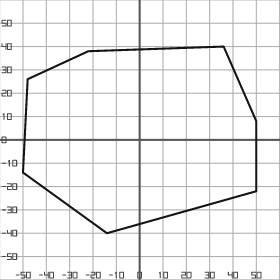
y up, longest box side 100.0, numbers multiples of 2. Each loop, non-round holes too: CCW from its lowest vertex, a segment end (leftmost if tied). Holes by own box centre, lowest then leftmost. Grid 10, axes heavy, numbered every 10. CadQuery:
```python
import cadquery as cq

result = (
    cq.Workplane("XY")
    .moveTo(-14.0, -40.0)
    .lineTo(50.0, -22.0)
    .lineTo(50.0, 8.0)
    .lineTo(36.0, 40.0)
    .lineTo(-22.0, 38.0)
    .lineTo(-48.0, 26.0)
    .lineTo(-50.0, -14.0)
    .close()
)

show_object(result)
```